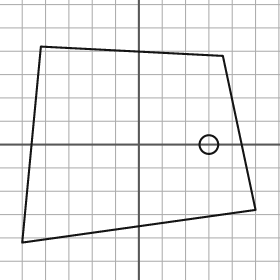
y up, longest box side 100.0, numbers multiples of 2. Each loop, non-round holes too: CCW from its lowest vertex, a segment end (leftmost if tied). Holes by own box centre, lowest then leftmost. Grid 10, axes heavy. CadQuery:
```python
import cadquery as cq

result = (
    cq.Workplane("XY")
    .moveTo(-50.0, -42.0)
    .lineTo(50.0, -28.0)
    .lineTo(36.0, 38.0)
    .lineTo(-42.0, 42.0)
    .close()
    .moveTo(30.0, 0.0)
    .circle(4.0)
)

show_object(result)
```